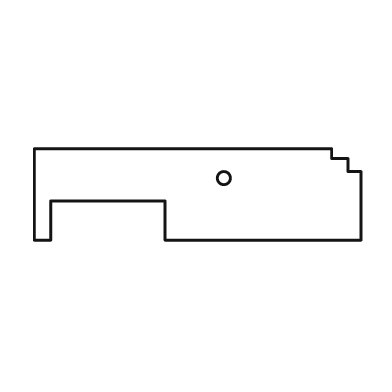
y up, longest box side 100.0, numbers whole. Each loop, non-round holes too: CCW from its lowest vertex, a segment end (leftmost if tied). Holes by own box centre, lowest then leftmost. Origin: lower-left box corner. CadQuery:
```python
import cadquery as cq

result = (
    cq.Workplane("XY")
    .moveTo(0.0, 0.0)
    .lineTo(5.0, 0.0)
    .lineTo(5.0, 12.0)
    .lineTo(40.0, 12.0)
    .lineTo(40.0, 0.0)
    .lineTo(100.0, 0.0)
    .lineTo(100.0, 21.0)
    .lineTo(96.0, 21.0)
    .lineTo(96.0, 25.0)
    .lineTo(91.0, 25.0)
    .lineTo(91.0, 28.0)
    .lineTo(0.0, 28.0)
    .close()
    .moveTo(58.0, 19.0)
    .circle(2.0)
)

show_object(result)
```